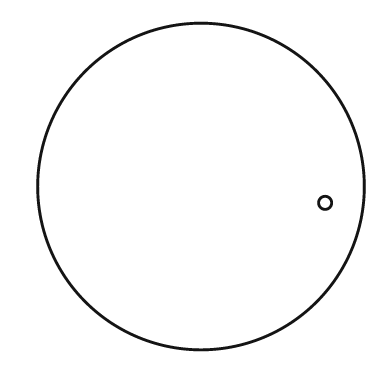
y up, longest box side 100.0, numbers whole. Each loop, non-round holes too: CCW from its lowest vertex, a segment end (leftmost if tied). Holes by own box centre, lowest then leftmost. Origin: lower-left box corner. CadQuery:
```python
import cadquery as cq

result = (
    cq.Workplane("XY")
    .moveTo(50.0, 50.0)
    .circle(50.0)
    .moveTo(88.0, 45.0)
    .circle(2.0)
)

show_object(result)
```